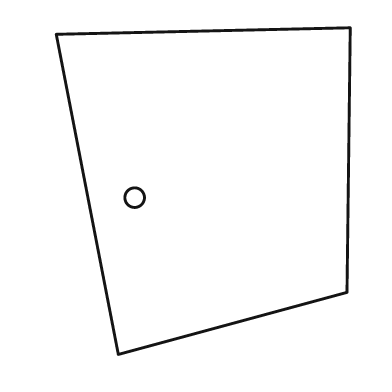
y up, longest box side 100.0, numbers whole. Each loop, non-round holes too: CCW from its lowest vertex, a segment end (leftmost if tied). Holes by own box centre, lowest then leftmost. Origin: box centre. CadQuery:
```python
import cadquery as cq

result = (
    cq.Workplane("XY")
    .moveTo(-26.0, -50.0)
    .lineTo(44.0, -31.0)
    .lineTo(45.0, 50.0)
    .lineTo(-45.0, 48.0)
    .close()
    .moveTo(-21.0, -2.0)
    .circle(3.0)
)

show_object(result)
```